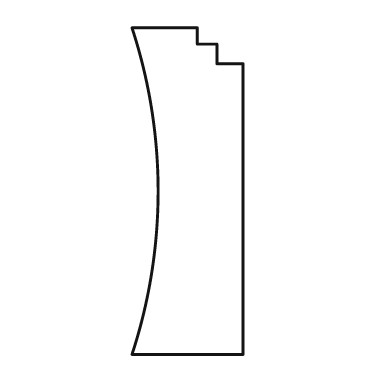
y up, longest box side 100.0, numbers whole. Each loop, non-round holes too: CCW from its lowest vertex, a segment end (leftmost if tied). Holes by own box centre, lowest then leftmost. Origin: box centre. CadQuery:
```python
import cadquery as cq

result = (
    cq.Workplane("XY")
    .moveTo(-17.0, -50.0)
    .lineTo(17.0, -50.0)
    .lineTo(17.0, 39.0)
    .lineTo(9.0, 39.0)
    .lineTo(9.0, 45.0)
    .lineTo(3.0, 45.0)
    .lineTo(3.0, 50.0)
    .lineTo(-17.0, 50.0)
    .threePointArc((-9.0, 0.0), (-17.0, -50.0))
    .close()
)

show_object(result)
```